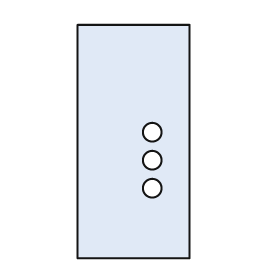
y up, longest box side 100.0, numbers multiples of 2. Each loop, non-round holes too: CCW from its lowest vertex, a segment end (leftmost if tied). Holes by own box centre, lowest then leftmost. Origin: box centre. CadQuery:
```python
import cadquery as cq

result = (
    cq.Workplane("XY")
    .moveTo(-24.0, -50.0)
    .lineTo(24.0, -50.0)
    .lineTo(24.0, 50.0)
    .lineTo(-24.0, 50.0)
    .close()
    .moveTo(8.0, -20.0)
    .circle(4.0)
    .moveTo(8.0, -8.0)
    .circle(4.0)
    .moveTo(8.0, 4.0)
    .circle(4.0)
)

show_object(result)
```